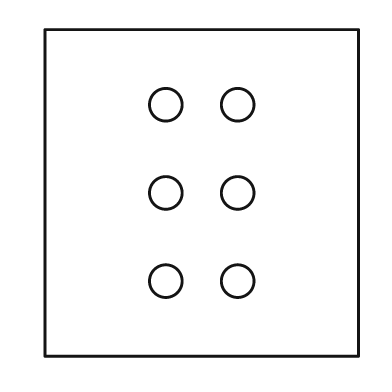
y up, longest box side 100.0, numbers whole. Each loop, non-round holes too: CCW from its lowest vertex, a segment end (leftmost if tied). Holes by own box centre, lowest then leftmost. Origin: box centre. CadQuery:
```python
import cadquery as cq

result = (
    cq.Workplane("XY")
    .moveTo(-48.0, -50.0)
    .lineTo(48.0, -50.0)
    .lineTo(48.0, 50.0)
    .lineTo(-48.0, 50.0)
    .close()
    .moveTo(-11.0, -27.0)
    .circle(5.0)
    .moveTo(11.0, -27.0)
    .circle(5.0)
    .moveTo(-11.0, 0.0)
    .circle(5.0)
    .moveTo(11.0, 0.0)
    .circle(5.0)
    .moveTo(-11.0, 27.0)
    .circle(5.0)
    .moveTo(11.0, 27.0)
    .circle(5.0)
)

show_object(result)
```